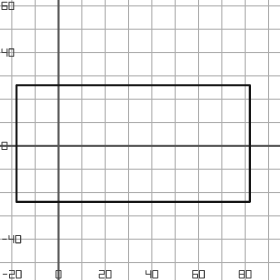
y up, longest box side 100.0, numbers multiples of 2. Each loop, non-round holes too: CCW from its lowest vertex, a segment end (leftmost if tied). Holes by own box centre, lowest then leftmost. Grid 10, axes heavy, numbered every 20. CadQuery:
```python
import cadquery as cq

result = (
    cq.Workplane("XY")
    .moveTo(-18.0, -24.0)
    .lineTo(82.0, -24.0)
    .lineTo(82.0, 26.0)
    .lineTo(-18.0, 26.0)
    .close()
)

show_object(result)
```